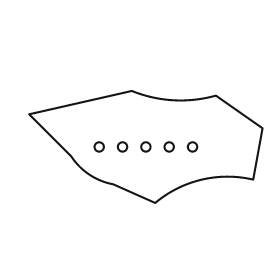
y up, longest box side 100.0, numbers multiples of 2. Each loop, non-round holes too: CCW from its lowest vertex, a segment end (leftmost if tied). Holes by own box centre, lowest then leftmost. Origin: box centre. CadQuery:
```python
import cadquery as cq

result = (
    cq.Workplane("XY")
    .moveTo(4.0, -24.0)
    .threePointArc((24.0, -14.0), (46.0, -14.0))
    .lineTo(50.0, 8.0)
    .lineTo(30.0, 22.0)
    .threePointArc((12.0, 20.0), (-6.0, 24.0))
    .lineTo(-50.0, 14.0)
    .lineTo(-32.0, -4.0)
    .threePointArc((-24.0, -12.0), (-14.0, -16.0))
    .close()
    .moveTo(-20.0, 0.0)
    .circle(2.0)
    .moveTo(-10.0, 0.0)
    .circle(2.0)
    .moveTo(0.0, 0.0)
    .circle(2.0)
    .moveTo(10.0, 0.0)
    .circle(2.0)
    .moveTo(20.0, 0.0)
    .circle(2.0)
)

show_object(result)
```